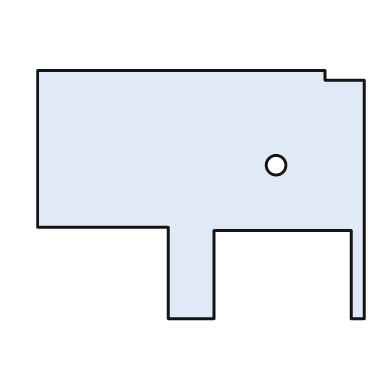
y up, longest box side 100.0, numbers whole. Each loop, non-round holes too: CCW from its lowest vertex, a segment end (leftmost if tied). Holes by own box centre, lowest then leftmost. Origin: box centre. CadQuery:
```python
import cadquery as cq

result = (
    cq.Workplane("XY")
    .moveTo(-10.0, -38.0)
    .lineTo(4.0, -38.0)
    .lineTo(4.0, -11.0)
    .lineTo(46.0, -11.0)
    .lineTo(46.0, -38.0)
    .lineTo(50.0, -38.0)
    .lineTo(50.0, 35.0)
    .lineTo(38.0, 35.0)
    .lineTo(38.0, 38.0)
    .lineTo(-50.0, 38.0)
    .lineTo(-50.0, -10.0)
    .lineTo(-10.0, -10.0)
    .close()
    .moveTo(23.0, 9.0)
    .circle(3.0)
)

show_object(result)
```